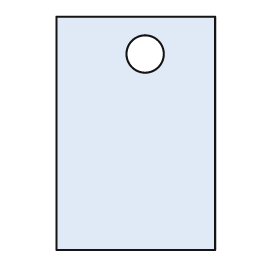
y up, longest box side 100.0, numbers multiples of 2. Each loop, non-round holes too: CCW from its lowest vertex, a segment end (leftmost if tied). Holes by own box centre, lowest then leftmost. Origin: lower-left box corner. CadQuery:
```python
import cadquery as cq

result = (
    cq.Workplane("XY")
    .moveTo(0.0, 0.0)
    .lineTo(68.0, 0.0)
    .lineTo(68.0, 100.0)
    .lineTo(0.0, 100.0)
    .close()
    .moveTo(38.0, 84.0)
    .circle(8.0)
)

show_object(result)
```